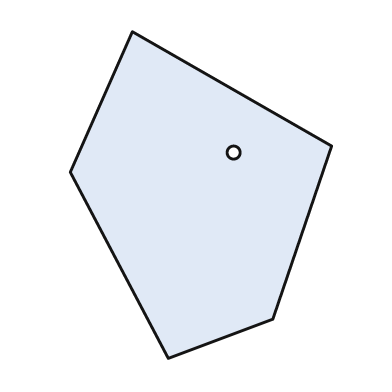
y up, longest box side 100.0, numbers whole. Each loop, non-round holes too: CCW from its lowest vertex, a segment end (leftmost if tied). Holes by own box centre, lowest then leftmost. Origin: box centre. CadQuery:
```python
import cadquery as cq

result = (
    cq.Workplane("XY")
    .moveTo(-10.0, -50.0)
    .lineTo(22.0, -38.0)
    .lineTo(40.0, 15.0)
    .lineTo(-21.0, 50.0)
    .lineTo(-40.0, 7.0)
    .close()
    .moveTo(10.0, 13.0)
    .circle(2.0)
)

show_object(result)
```